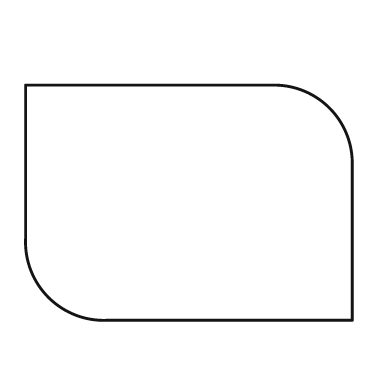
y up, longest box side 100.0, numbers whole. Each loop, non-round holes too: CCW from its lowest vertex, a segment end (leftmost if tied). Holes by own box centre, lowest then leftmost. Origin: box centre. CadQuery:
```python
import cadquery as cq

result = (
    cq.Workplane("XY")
    .moveTo(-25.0, -36.0)
    .lineTo(50.0, -36.0)
    .lineTo(50.0, 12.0)
    .threePointArc((43.0, 29.0), (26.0, 36.0))
    .lineTo(-50.0, 36.0)
    .lineTo(-50.0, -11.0)
    .threePointArc((-43.0, -29.0), (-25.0, -36.0))
    .close()
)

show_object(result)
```